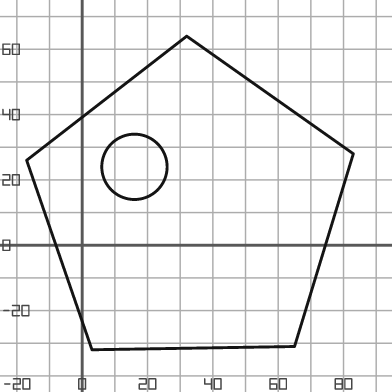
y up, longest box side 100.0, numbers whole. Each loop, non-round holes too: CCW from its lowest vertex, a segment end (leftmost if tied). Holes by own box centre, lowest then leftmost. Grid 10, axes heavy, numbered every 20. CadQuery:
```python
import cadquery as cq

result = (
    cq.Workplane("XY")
    .moveTo(3.0, -32.0)
    .lineTo(65.0, -31.0)
    .lineTo(83.0, 28.0)
    .lineTo(32.0, 64.0)
    .lineTo(-17.0, 26.0)
    .close()
    .moveTo(16.0, 24.0)
    .circle(10.0)
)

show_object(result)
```